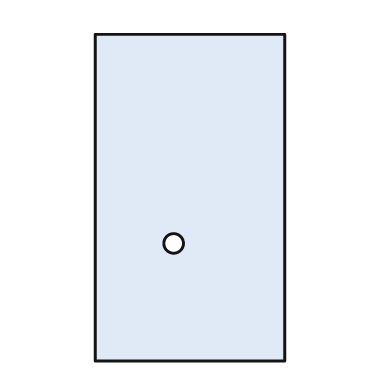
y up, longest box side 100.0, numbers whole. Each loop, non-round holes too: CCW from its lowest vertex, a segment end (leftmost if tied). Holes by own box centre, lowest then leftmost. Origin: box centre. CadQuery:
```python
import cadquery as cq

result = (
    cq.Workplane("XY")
    .moveTo(-29.0, -50.0)
    .lineTo(29.0, -50.0)
    .lineTo(29.0, 50.0)
    .lineTo(-29.0, 50.0)
    .close()
    .moveTo(-5.0, -14.0)
    .circle(3.0)
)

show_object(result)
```